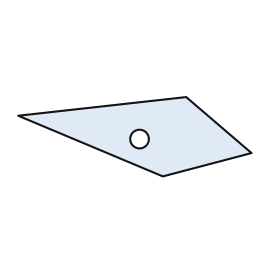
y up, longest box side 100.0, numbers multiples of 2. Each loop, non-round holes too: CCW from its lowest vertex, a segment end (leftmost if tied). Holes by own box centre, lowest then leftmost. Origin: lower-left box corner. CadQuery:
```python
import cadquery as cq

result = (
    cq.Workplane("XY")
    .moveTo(62.0, 0.0)
    .lineTo(100.0, 10.0)
    .lineTo(72.0, 34.0)
    .lineTo(0.0, 26.0)
    .close()
    .moveTo(52.0, 16.0)
    .circle(4.0)
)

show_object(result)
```